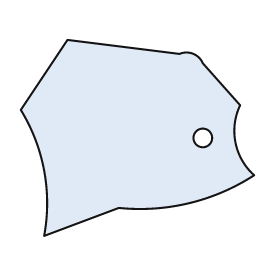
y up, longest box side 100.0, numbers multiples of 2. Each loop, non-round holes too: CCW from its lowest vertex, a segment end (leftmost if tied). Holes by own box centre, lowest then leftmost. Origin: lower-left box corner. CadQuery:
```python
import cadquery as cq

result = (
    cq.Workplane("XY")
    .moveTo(10.0, 0.0)
    .lineTo(42.0, 12.0)
    .threePointArc((72.0, 14.0), (100.0, 26.0))
    .threePointArc((92.0, 40.0), (94.0, 56.0))
    .lineTo(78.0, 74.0)
    .threePointArc((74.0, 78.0), (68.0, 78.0))
    .lineTo(20.0, 84.0)
    .lineTo(0.0, 54.0)
    .threePointArc((10.0, 28.0), (10.0, 0.0))
    .close()
    .moveTo(78.0, 42.0)
    .circle(4.0)
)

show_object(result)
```